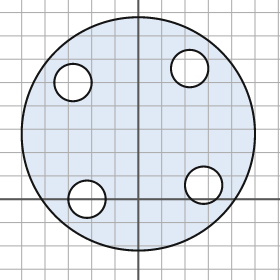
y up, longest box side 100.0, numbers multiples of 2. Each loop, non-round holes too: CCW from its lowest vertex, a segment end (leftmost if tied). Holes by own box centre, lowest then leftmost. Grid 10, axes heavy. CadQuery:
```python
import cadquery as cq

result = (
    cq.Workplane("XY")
    .moveTo(0.0, 28.0)
    .circle(50.0)
    .moveTo(-22.0, 0.0)
    .circle(8.0)
    .moveTo(28.0, 6.0)
    .circle(8.0)
    .moveTo(-28.0, 50.0)
    .circle(8.0)
    .moveTo(22.0, 56.0)
    .circle(8.0)
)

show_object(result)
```